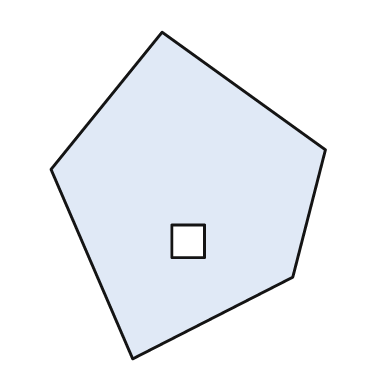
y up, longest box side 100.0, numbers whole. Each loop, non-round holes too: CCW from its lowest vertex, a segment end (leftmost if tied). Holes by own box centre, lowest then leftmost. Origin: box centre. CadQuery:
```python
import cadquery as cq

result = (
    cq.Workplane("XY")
    .moveTo(-17.0, -50.0)
    .lineTo(32.0, -25.0)
    .lineTo(42.0, 14.0)
    .lineTo(-8.0, 50.0)
    .lineTo(-42.0, 8.0)
    .close()
    .moveTo(-5.0, -19.0)
    .lineTo(5.0, -19.0)
    .lineTo(5.0, -9.0)
    .lineTo(-5.0, -9.0)
    .close()
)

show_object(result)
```